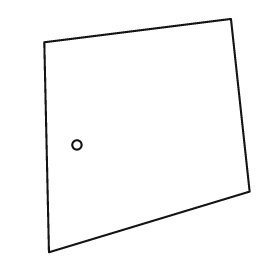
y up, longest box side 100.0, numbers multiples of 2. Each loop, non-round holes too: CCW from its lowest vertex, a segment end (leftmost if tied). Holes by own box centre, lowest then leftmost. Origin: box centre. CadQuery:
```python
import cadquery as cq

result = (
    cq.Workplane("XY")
    .moveTo(-42.0, -50.0)
    .lineTo(44.0, -24.0)
    .lineTo(36.0, 50.0)
    .lineTo(-44.0, 40.0)
    .close()
    .moveTo(-30.0, -4.0)
    .circle(2.0)
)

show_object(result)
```